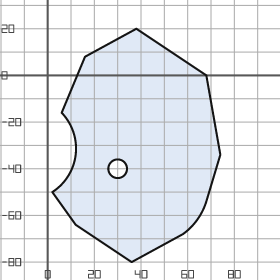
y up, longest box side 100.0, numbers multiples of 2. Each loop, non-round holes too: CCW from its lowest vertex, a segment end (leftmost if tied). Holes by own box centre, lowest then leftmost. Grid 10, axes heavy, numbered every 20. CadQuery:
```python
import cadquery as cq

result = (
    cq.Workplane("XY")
    .moveTo(36.0, -80.0)
    .lineTo(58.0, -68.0)
    .threePointArc((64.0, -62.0), (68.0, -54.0))
    .lineTo(74.0, -34.0)
    .lineTo(68.0, 0.0)
    .lineTo(38.0, 20.0)
    .lineTo(16.0, 8.0)
    .lineTo(6.0, -16.0)
    .threePointArc((12.0, -34.0), (2.0, -50.0))
    .lineTo(12.0, -64.0)
    .close()
    .moveTo(30.0, -40.0)
    .circle(4.0)
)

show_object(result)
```